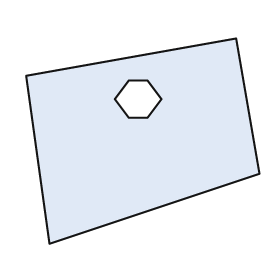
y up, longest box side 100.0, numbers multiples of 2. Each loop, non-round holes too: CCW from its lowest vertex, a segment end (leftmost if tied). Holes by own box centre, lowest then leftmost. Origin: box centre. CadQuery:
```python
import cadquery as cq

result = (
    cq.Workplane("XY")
    .moveTo(-40.0, -44.0)
    .lineTo(50.0, -14.0)
    .lineTo(40.0, 44.0)
    .lineTo(-50.0, 28.0)
    .close()
    .moveTo(-6.0, 10.0)
    .lineTo(2.0, 10.0)
    .lineTo(8.0, 18.0)
    .lineTo(2.0, 26.0)
    .lineTo(-6.0, 26.0)
    .lineTo(-12.0, 18.0)
    .close()
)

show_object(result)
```